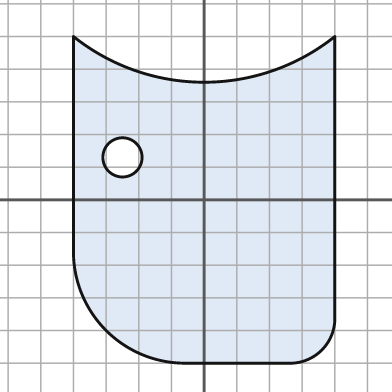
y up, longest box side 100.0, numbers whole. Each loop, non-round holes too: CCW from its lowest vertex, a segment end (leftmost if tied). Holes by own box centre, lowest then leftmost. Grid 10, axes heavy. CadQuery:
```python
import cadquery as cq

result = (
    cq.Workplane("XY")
    .moveTo(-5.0, -50.0)
    .lineTo(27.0, -50.0)
    .threePointArc((36.0, -46.0), (40.0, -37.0))
    .lineTo(40.0, 50.0)
    .threePointArc((0.0, 36.0), (-40.0, 50.0))
    .lineTo(-40.0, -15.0)
    .threePointArc((-30.0, -40.0), (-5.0, -50.0))
    .close()
    .moveTo(-25.0, 13.0)
    .circle(6.0)
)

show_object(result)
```